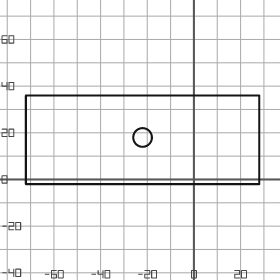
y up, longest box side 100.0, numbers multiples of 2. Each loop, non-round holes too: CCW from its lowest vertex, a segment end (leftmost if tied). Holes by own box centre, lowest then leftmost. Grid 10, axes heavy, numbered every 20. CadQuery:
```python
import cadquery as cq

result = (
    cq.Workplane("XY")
    .moveTo(-72.0, -2.0)
    .lineTo(28.0, -2.0)
    .lineTo(28.0, 36.0)
    .lineTo(-72.0, 36.0)
    .close()
    .moveTo(-22.0, 18.0)
    .circle(4.0)
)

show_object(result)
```